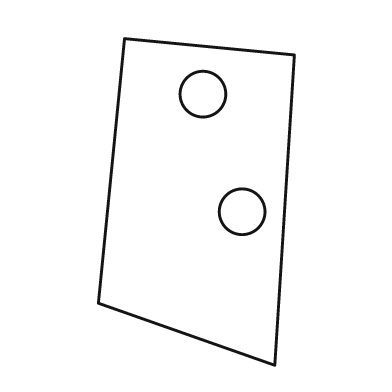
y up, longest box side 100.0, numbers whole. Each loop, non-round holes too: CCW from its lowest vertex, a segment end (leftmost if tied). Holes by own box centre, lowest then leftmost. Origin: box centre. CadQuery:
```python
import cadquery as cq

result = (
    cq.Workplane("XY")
    .moveTo(24.0, -50.0)
    .lineTo(30.0, 45.0)
    .lineTo(-22.0, 50.0)
    .lineTo(-30.0, -31.0)
    .close()
    .moveTo(14.0, -3.0)
    .circle(7.0)
    .moveTo(2.0, 33.0)
    .circle(7.0)
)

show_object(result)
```